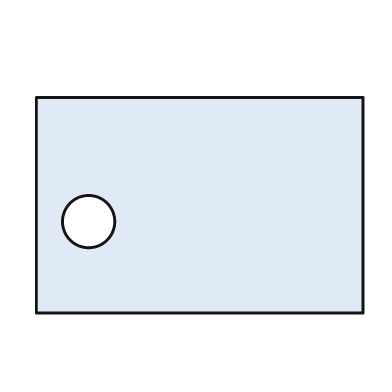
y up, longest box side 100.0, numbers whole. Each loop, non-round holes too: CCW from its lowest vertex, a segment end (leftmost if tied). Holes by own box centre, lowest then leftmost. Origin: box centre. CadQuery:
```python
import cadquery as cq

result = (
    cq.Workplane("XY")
    .moveTo(-50.0, -33.0)
    .lineTo(50.0, -33.0)
    .lineTo(50.0, 33.0)
    .lineTo(-50.0, 33.0)
    .close()
    .moveTo(-34.0, -5.0)
    .circle(8.0)
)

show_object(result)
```